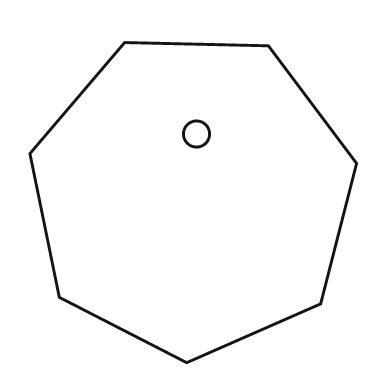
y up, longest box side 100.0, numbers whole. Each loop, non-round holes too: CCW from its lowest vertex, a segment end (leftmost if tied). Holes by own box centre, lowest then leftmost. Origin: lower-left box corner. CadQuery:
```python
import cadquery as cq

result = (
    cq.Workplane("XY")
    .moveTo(48.0, 0.0)
    .lineTo(89.0, 18.0)
    .lineTo(100.0, 61.0)
    .lineTo(73.0, 97.0)
    .lineTo(29.0, 98.0)
    .lineTo(0.0, 64.0)
    .lineTo(9.0, 20.0)
    .close()
    .moveTo(51.0, 70.0)
    .circle(4.0)
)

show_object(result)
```